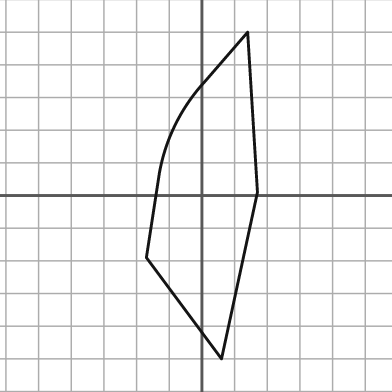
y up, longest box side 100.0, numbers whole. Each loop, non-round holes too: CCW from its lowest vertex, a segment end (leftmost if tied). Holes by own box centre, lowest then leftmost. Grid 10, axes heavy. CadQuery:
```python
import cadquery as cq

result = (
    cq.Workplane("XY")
    .moveTo(6.0, -50.0)
    .lineTo(17.0, 1.0)
    .lineTo(14.0, 50.0)
    .lineTo(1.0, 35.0)
    .threePointArc((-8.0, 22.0), (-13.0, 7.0))
    .lineTo(-17.0, -19.0)
    .close()
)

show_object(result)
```